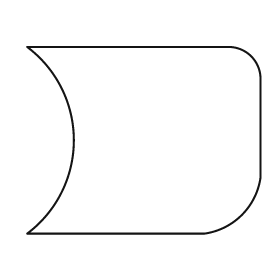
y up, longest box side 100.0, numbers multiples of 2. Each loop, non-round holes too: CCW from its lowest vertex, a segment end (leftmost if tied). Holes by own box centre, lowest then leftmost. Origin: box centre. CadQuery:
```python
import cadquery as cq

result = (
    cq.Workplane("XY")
    .moveTo(-50.0, -40.0)
    .lineTo(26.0, -40.0)
    .threePointArc((42.0, -32.0), (50.0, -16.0))
    .lineTo(50.0, 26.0)
    .threePointArc((46.0, 36.0), (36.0, 40.0))
    .lineTo(-50.0, 40.0)
    .threePointArc((-30.0, 0.0), (-50.0, -40.0))
    .close()
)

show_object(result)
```